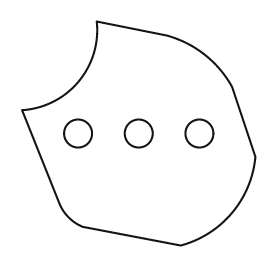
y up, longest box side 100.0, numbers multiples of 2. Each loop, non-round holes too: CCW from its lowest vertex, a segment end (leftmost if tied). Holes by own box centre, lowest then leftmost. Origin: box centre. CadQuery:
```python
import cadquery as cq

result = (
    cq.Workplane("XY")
    .moveTo(18.0, -48.0)
    .threePointArc((40.0, -34.0), (50.0, -10.0))
    .lineTo(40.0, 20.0)
    .threePointArc((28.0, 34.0), (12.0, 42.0))
    .lineTo(-18.0, 48.0)
    .threePointArc((-26.0, 22.0), (-50.0, 10.0))
    .lineTo(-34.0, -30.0)
    .threePointArc((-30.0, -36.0), (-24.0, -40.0))
    .close()
    .moveTo(-26.0, 0.0)
    .circle(6.0)
    .moveTo(0.0, 0.0)
    .circle(6.0)
    .moveTo(26.0, 0.0)
    .circle(6.0)
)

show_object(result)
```